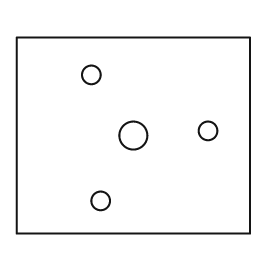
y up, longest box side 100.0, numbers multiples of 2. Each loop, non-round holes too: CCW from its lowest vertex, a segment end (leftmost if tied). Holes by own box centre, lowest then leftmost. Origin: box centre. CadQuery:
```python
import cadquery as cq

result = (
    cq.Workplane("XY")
    .moveTo(-50.0, -42.0)
    .lineTo(50.0, -42.0)
    .lineTo(50.0, 42.0)
    .lineTo(-50.0, 42.0)
    .close()
    .moveTo(-14.0, -28.0)
    .circle(4.0)
    .moveTo(0.0, 0.0)
    .circle(6.0)
    .moveTo(32.0, 2.0)
    .circle(4.0)
    .moveTo(-18.0, 26.0)
    .circle(4.0)
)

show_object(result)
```